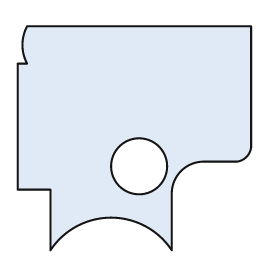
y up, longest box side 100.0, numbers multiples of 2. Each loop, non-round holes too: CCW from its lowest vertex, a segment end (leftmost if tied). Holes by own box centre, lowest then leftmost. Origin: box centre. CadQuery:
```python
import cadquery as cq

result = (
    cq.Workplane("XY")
    .moveTo(-36.0, -48.0)
    .threePointArc((-10.0, -34.0), (16.0, -48.0))
    .lineTo(16.0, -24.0)
    .threePointArc((20.0, -14.0), (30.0, -10.0))
    .lineTo(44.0, -10.0)
    .threePointArc((48.0, -8.0), (50.0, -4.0))
    .lineTo(50.0, 48.0)
    .lineTo(-46.0, 48.0)
    .threePointArc((-48.0, 40.0), (-46.0, 32.0))
    .lineTo(-50.0, 32.0)
    .lineTo(-50.0, -22.0)
    .lineTo(-36.0, -22.0)
    .close()
    .moveTo(2.0, -12.0)
    .circle(12.0)
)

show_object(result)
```